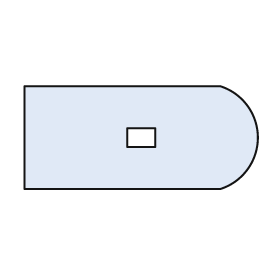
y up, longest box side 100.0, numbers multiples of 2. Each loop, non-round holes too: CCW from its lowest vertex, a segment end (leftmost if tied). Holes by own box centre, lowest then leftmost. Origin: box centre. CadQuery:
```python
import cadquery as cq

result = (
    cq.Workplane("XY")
    .moveTo(-50.0, -22.0)
    .lineTo(34.0, -22.0)
    .threePointArc((50.0, 0.0), (34.0, 22.0))
    .lineTo(-50.0, 22.0)
    .close()
    .moveTo(-6.0, -4.0)
    .lineTo(6.0, -4.0)
    .lineTo(6.0, 4.0)
    .lineTo(-6.0, 4.0)
    .close()
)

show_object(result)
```